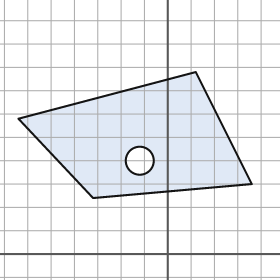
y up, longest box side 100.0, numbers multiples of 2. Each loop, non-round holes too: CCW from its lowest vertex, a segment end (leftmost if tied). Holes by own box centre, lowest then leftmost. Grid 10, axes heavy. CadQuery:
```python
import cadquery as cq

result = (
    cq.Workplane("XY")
    .moveTo(-32.0, 24.0)
    .lineTo(36.0, 30.0)
    .lineTo(12.0, 78.0)
    .lineTo(-64.0, 58.0)
    .close()
    .moveTo(-12.0, 40.0)
    .circle(6.0)
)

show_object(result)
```